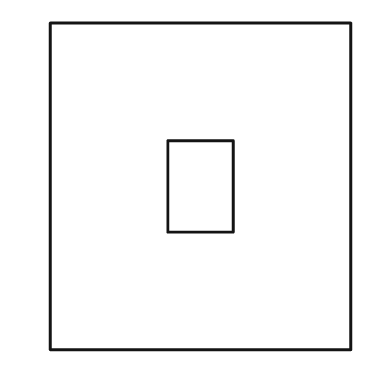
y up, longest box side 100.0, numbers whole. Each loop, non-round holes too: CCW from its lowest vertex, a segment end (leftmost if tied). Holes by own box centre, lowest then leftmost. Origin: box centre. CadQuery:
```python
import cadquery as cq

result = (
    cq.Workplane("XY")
    .moveTo(-46.0, -50.0)
    .lineTo(46.0, -50.0)
    .lineTo(46.0, 50.0)
    .lineTo(-46.0, 50.0)
    .close()
    .moveTo(-10.0, -14.0)
    .lineTo(10.0, -14.0)
    .lineTo(10.0, 14.0)
    .lineTo(-10.0, 14.0)
    .close()
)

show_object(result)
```